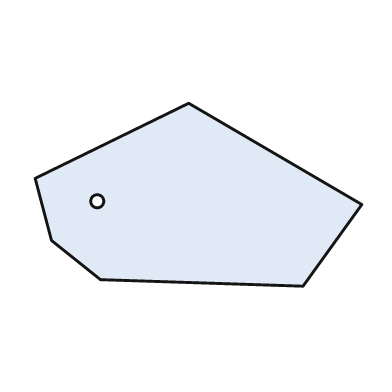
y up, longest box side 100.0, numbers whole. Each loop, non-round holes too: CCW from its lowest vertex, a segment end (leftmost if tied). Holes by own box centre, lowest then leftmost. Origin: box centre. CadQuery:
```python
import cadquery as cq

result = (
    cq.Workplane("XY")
    .moveTo(32.0, -28.0)
    .lineTo(50.0, -3.0)
    .lineTo(-3.0, 28.0)
    .lineTo(-50.0, 5.0)
    .lineTo(-45.0, -14.0)
    .lineTo(-30.0, -26.0)
    .close()
    .moveTo(-31.0, -2.0)
    .circle(2.0)
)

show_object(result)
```